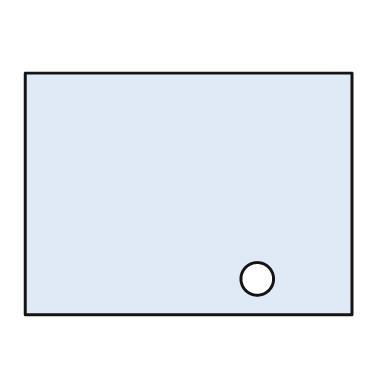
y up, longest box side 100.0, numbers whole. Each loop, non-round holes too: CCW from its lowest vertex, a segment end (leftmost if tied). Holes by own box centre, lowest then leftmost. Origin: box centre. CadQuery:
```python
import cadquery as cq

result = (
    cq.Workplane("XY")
    .moveTo(-50.0, -37.0)
    .lineTo(50.0, -37.0)
    .lineTo(50.0, 37.0)
    .lineTo(-50.0, 37.0)
    .close()
    .moveTo(21.0, -26.0)
    .circle(5.0)
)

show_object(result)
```